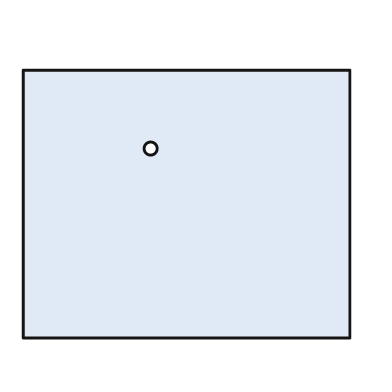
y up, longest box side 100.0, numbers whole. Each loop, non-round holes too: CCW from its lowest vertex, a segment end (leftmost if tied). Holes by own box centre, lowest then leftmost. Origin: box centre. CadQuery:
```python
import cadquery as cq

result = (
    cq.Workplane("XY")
    .moveTo(-50.0, -41.0)
    .lineTo(50.0, -41.0)
    .lineTo(50.0, 41.0)
    .lineTo(-50.0, 41.0)
    .close()
    .moveTo(-11.0, 17.0)
    .circle(2.0)
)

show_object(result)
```